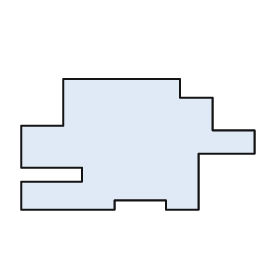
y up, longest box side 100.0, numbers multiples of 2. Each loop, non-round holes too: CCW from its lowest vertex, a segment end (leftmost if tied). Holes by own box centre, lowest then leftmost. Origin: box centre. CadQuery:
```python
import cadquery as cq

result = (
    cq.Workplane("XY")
    .moveTo(-50.0, -28.0)
    .lineTo(-10.0, -28.0)
    .lineTo(-10.0, -24.0)
    .lineTo(12.0, -24.0)
    .lineTo(12.0, -28.0)
    .lineTo(26.0, -28.0)
    .lineTo(26.0, -4.0)
    .lineTo(50.0, -4.0)
    .lineTo(50.0, 6.0)
    .lineTo(32.0, 6.0)
    .lineTo(32.0, 20.0)
    .lineTo(18.0, 20.0)
    .lineTo(18.0, 28.0)
    .lineTo(-32.0, 28.0)
    .lineTo(-32.0, 8.0)
    .lineTo(-50.0, 8.0)
    .lineTo(-50.0, -10.0)
    .lineTo(-24.0, -10.0)
    .lineTo(-24.0, -16.0)
    .lineTo(-50.0, -16.0)
    .close()
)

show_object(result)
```